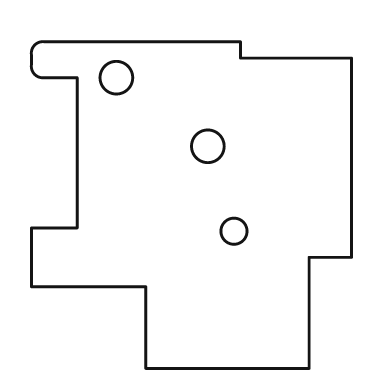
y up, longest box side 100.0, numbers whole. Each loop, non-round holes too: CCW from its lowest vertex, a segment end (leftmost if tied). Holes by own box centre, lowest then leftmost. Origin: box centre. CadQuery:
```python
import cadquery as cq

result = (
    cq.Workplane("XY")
    .moveTo(-14.0, -50.0)
    .lineTo(36.0, -50.0)
    .lineTo(36.0, -16.0)
    .lineTo(49.0, -16.0)
    .lineTo(49.0, 45.0)
    .lineTo(15.0, 45.0)
    .lineTo(15.0, 50.0)
    .lineTo(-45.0, 50.0)
    .threePointArc((-48.0, 49.0), (-49.0, 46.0))
    .lineTo(-49.0, 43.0)
    .threePointArc((-48.0, 40.0), (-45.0, 39.0))
    .lineTo(-35.0, 39.0)
    .lineTo(-35.0, -7.0)
    .lineTo(-49.0, -7.0)
    .lineTo(-49.0, -25.0)
    .lineTo(-14.0, -25.0)
    .close()
    .moveTo(13.0, -8.0)
    .circle(4.0)
    .moveTo(5.0, 18.0)
    .circle(5.0)
    .moveTo(-23.0, 39.0)
    .circle(5.0)
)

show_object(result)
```